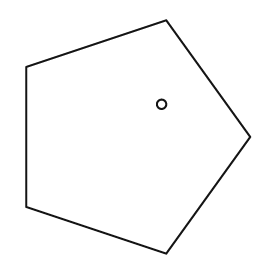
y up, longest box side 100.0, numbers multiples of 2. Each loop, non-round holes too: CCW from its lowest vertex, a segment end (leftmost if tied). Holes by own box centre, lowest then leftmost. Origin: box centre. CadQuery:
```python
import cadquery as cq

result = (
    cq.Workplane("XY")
    .moveTo(12.0, -50.0)
    .lineTo(48.0, 0.0)
    .lineTo(12.0, 50.0)
    .lineTo(-48.0, 30.0)
    .lineTo(-48.0, -30.0)
    .close()
    .moveTo(10.0, 14.0)
    .circle(2.0)
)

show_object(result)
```